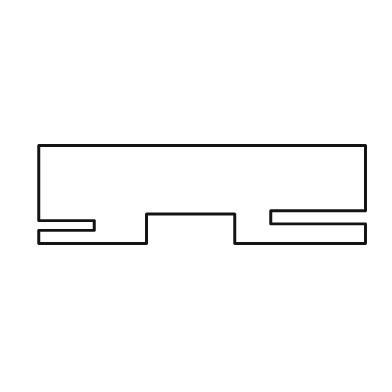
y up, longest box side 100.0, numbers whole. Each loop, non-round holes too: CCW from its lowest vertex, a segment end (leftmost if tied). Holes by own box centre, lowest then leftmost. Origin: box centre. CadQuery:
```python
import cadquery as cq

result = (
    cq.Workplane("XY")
    .moveTo(-50.0, -15.0)
    .lineTo(-17.0, -15.0)
    .lineTo(-17.0, -6.0)
    .lineTo(10.0, -6.0)
    .lineTo(10.0, -15.0)
    .lineTo(50.0, -15.0)
    .lineTo(50.0, -9.0)
    .lineTo(21.0, -9.0)
    .lineTo(21.0, -5.0)
    .lineTo(50.0, -5.0)
    .lineTo(50.0, 15.0)
    .lineTo(-50.0, 15.0)
    .lineTo(-50.0, -8.0)
    .lineTo(-33.0, -8.0)
    .lineTo(-33.0, -11.0)
    .lineTo(-50.0, -11.0)
    .close()
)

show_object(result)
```